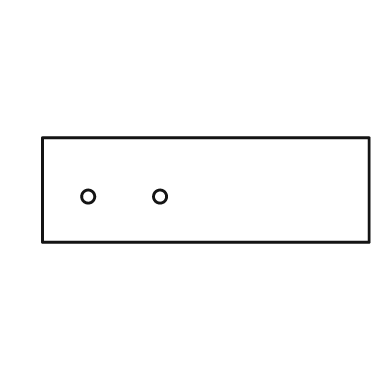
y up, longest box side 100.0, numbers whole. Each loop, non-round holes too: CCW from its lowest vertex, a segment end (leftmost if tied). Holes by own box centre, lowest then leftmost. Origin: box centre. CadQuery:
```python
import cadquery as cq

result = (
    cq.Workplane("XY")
    .moveTo(-50.0, -16.0)
    .lineTo(50.0, -16.0)
    .lineTo(50.0, 16.0)
    .lineTo(-50.0, 16.0)
    .close()
    .moveTo(-36.0, -2.0)
    .circle(2.0)
    .moveTo(-14.0, -2.0)
    .circle(2.0)
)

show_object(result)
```